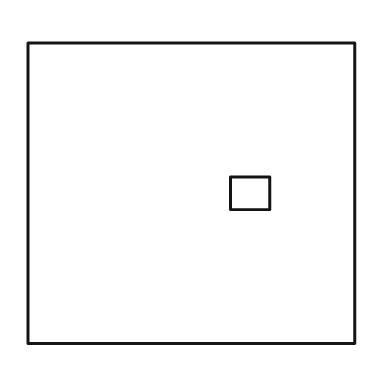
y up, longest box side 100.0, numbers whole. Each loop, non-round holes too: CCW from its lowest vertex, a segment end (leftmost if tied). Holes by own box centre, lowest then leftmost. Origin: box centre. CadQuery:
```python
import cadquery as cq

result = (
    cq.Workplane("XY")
    .moveTo(-50.0, -46.0)
    .lineTo(50.0, -46.0)
    .lineTo(50.0, 46.0)
    .lineTo(-50.0, 46.0)
    .close()
    .moveTo(12.0, -5.0)
    .lineTo(24.0, -5.0)
    .lineTo(24.0, 5.0)
    .lineTo(12.0, 5.0)
    .close()
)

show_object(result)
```